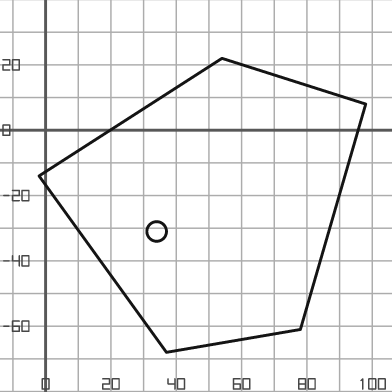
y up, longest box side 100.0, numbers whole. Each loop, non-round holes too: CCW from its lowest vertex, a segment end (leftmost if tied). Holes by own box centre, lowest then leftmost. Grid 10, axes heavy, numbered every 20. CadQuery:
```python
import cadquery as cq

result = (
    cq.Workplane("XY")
    .moveTo(37.0, -68.0)
    .lineTo(78.0, -61.0)
    .lineTo(98.0, 8.0)
    .lineTo(54.0, 22.0)
    .lineTo(-2.0, -14.0)
    .close()
    .moveTo(34.0, -31.0)
    .circle(3.0)
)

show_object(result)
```